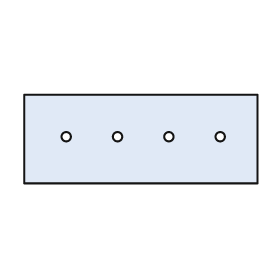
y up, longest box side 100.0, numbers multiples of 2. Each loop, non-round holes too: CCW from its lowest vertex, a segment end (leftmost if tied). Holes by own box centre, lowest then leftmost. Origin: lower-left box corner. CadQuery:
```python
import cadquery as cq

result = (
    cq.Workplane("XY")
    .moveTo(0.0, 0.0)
    .lineTo(100.0, 0.0)
    .lineTo(100.0, 38.0)
    .lineTo(0.0, 38.0)
    .close()
    .moveTo(18.0, 20.0)
    .circle(2.0)
    .moveTo(40.0, 20.0)
    .circle(2.0)
    .moveTo(62.0, 20.0)
    .circle(2.0)
    .moveTo(84.0, 20.0)
    .circle(2.0)
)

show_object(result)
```